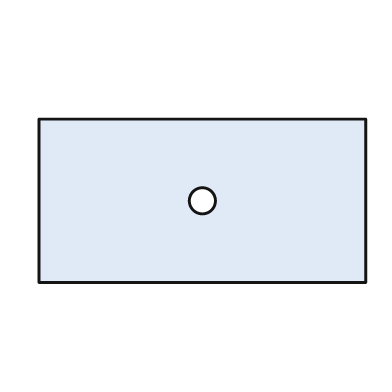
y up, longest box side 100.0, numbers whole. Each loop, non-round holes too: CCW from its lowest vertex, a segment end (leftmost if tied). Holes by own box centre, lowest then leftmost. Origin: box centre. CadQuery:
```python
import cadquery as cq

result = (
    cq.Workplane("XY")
    .moveTo(-50.0, -25.0)
    .lineTo(50.0, -25.0)
    .lineTo(50.0, 25.0)
    .lineTo(-50.0, 25.0)
    .close()
    .moveTo(0.0, 0.0)
    .circle(4.0)
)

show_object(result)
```